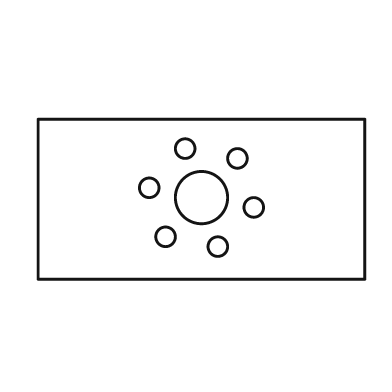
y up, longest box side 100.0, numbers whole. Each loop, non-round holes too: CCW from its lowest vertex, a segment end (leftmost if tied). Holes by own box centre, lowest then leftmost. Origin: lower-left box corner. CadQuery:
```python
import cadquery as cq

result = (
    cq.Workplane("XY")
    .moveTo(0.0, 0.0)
    .lineTo(100.0, 0.0)
    .lineTo(100.0, 49.0)
    .lineTo(0.0, 49.0)
    .close()
    .moveTo(55.0, 10.0)
    .circle(3.0)
    .moveTo(39.0, 13.0)
    .circle(3.0)
    .moveTo(66.0, 22.0)
    .circle(3.0)
    .moveTo(50.0, 25.0)
    .circle(8.0)
    .moveTo(34.0, 28.0)
    .circle(3.0)
    .moveTo(61.0, 37.0)
    .circle(3.0)
    .moveTo(45.0, 40.0)
    .circle(3.0)
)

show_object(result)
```